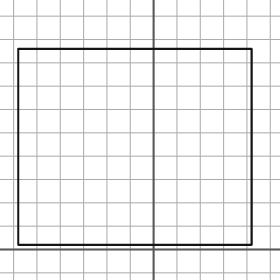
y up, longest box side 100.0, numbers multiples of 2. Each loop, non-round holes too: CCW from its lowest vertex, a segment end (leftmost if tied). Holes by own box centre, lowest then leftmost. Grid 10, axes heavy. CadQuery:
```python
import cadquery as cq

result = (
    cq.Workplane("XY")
    .moveTo(-58.0, 2.0)
    .lineTo(42.0, 2.0)
    .lineTo(42.0, 86.0)
    .lineTo(-58.0, 86.0)
    .close()
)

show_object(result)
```